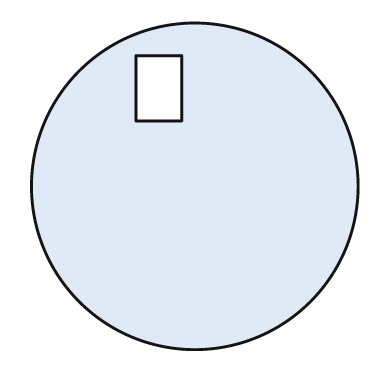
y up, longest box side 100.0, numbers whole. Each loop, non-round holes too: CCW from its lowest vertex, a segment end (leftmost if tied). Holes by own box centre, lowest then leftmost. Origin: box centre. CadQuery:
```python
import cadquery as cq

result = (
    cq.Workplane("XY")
    .moveTo(0.0, 0.0)
    .circle(50.0)
    .moveTo(-18.0, 20.0)
    .lineTo(-4.0, 20.0)
    .lineTo(-4.0, 40.0)
    .lineTo(-18.0, 40.0)
    .close()
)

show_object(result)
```